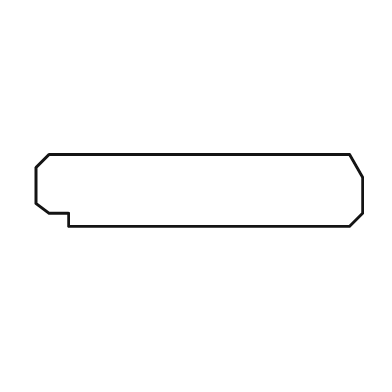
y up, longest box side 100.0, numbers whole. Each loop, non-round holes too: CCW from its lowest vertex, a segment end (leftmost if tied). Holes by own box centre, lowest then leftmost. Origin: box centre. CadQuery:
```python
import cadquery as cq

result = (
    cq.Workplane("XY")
    .moveTo(-40.0, -11.0)
    .lineTo(46.0, -11.0)
    .lineTo(50.0, -7.0)
    .lineTo(50.0, 4.0)
    .lineTo(46.0, 11.0)
    .lineTo(-46.0, 11.0)
    .lineTo(-50.0, 7.0)
    .lineTo(-50.0, -4.0)
    .lineTo(-46.0, -7.0)
    .lineTo(-40.0, -7.0)
    .close()
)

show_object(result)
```